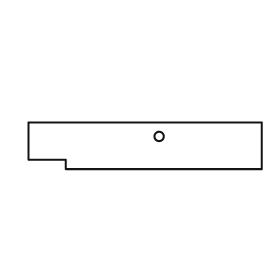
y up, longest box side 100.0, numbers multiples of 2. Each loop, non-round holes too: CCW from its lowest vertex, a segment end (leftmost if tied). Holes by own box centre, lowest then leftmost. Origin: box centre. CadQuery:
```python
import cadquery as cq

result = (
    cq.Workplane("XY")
    .moveTo(-34.0, -10.0)
    .lineTo(50.0, -10.0)
    .lineTo(50.0, 10.0)
    .lineTo(-50.0, 10.0)
    .lineTo(-50.0, -6.0)
    .lineTo(-34.0, -6.0)
    .close()
    .moveTo(6.0, 4.0)
    .circle(2.0)
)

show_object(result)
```